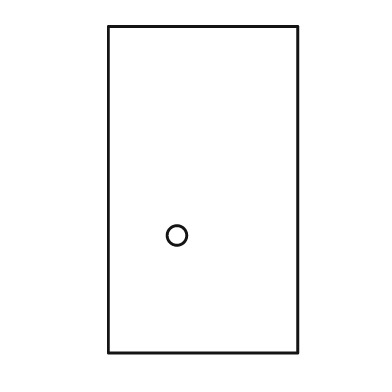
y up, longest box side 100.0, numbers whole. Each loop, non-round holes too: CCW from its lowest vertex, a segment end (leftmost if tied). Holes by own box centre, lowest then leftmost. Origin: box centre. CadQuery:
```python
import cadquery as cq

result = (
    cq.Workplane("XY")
    .moveTo(-29.0, -50.0)
    .lineTo(29.0, -50.0)
    .lineTo(29.0, 50.0)
    .lineTo(-29.0, 50.0)
    .close()
    .moveTo(-8.0, -14.0)
    .circle(3.0)
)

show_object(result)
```